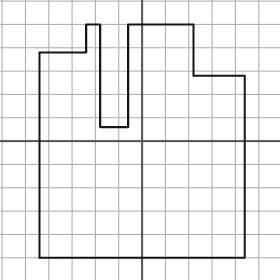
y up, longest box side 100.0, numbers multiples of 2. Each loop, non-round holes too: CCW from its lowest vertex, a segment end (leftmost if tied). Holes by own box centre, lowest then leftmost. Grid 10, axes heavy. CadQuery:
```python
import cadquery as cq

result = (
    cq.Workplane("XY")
    .moveTo(-44.0, -50.0)
    .lineTo(44.0, -50.0)
    .lineTo(44.0, 28.0)
    .lineTo(22.0, 28.0)
    .lineTo(22.0, 50.0)
    .lineTo(-6.0, 50.0)
    .lineTo(-6.0, 6.0)
    .lineTo(-18.0, 6.0)
    .lineTo(-18.0, 50.0)
    .lineTo(-24.0, 50.0)
    .lineTo(-24.0, 38.0)
    .lineTo(-44.0, 38.0)
    .close()
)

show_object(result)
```